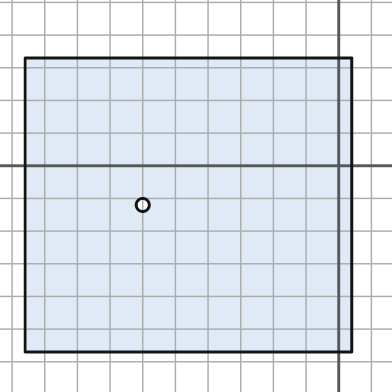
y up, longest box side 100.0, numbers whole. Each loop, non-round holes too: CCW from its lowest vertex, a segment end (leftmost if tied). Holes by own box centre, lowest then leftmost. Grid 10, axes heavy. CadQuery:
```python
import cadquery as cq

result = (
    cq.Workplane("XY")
    .moveTo(-96.0, -57.0)
    .lineTo(4.0, -57.0)
    .lineTo(4.0, 33.0)
    .lineTo(-96.0, 33.0)
    .close()
    .moveTo(-60.0, -12.0)
    .circle(2.0)
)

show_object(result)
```